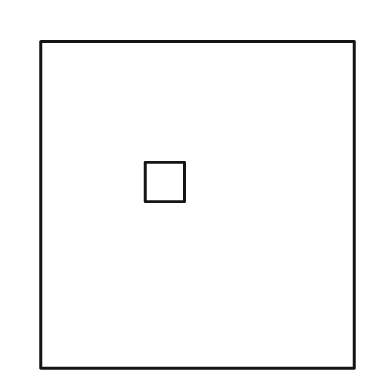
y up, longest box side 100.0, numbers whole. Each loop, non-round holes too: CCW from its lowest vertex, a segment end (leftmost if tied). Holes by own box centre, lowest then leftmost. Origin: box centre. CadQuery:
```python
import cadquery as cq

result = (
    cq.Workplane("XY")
    .moveTo(-48.0, -50.0)
    .lineTo(48.0, -50.0)
    .lineTo(48.0, 50.0)
    .lineTo(-48.0, 50.0)
    .close()
    .moveTo(-16.0, 1.0)
    .lineTo(-4.0, 1.0)
    .lineTo(-4.0, 13.0)
    .lineTo(-16.0, 13.0)
    .close()
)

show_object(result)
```